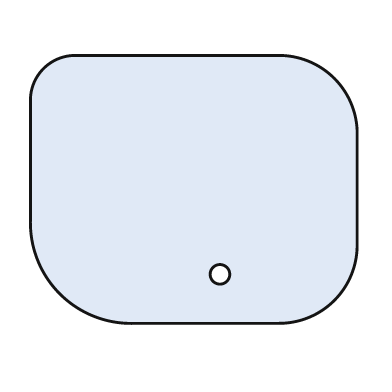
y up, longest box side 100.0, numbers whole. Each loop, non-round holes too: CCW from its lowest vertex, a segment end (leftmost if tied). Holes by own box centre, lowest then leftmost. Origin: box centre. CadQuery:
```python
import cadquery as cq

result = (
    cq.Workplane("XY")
    .moveTo(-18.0, -41.0)
    .lineTo(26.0, -41.0)
    .threePointArc((43.0, -34.0), (50.0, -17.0))
    .lineTo(50.0, 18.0)
    .threePointArc((43.0, 34.0), (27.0, 41.0))
    .lineTo(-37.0, 41.0)
    .threePointArc((-46.0, 37.0), (-50.0, 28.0))
    .lineTo(-50.0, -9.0)
    .threePointArc((-41.0, -32.0), (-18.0, -41.0))
    .close()
    .moveTo(8.0, -26.0)
    .circle(3.0)
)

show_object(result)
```